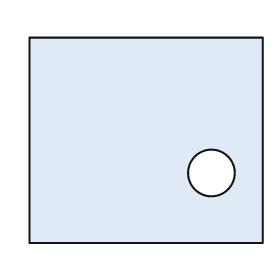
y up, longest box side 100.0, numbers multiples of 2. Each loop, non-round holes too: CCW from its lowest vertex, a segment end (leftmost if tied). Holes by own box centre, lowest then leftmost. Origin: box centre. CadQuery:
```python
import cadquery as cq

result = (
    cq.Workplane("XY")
    .moveTo(-50.0, -44.0)
    .lineTo(50.0, -44.0)
    .lineTo(50.0, 44.0)
    .lineTo(-50.0, 44.0)
    .close()
    .moveTo(28.0, -14.0)
    .circle(10.0)
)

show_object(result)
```